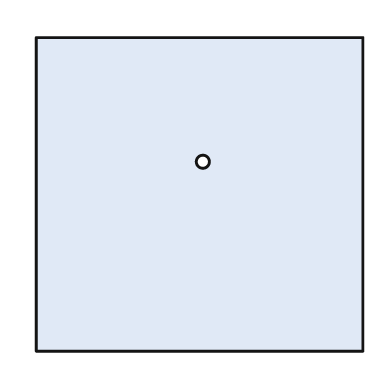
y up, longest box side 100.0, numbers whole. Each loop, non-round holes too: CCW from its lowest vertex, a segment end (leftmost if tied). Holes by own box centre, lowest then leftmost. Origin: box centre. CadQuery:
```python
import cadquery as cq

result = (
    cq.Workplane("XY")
    .moveTo(-50.0, -48.0)
    .lineTo(50.0, -48.0)
    .lineTo(50.0, 48.0)
    .lineTo(-50.0, 48.0)
    .close()
    .moveTo(1.0, 10.0)
    .circle(2.0)
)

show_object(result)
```